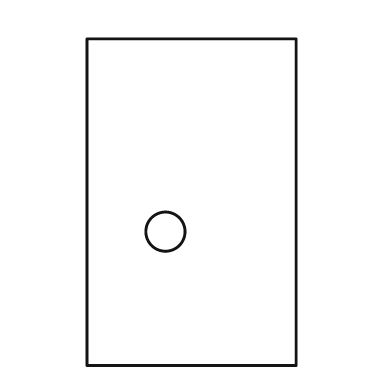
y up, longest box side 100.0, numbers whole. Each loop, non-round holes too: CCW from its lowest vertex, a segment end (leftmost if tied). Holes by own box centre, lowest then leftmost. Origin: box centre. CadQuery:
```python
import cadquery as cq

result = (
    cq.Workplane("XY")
    .moveTo(-32.0, -50.0)
    .lineTo(32.0, -50.0)
    .lineTo(32.0, 50.0)
    .lineTo(-32.0, 50.0)
    .close()
    .moveTo(-8.0, -9.0)
    .circle(6.0)
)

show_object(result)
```